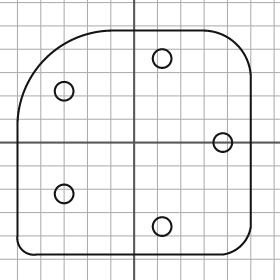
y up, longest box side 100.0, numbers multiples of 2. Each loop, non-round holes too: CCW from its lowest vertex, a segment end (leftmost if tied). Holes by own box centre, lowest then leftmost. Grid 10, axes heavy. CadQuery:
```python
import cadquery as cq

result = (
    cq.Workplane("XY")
    .moveTo(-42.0, -48.0)
    .lineTo(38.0, -48.0)
    .threePointArc((46.0, -44.0), (50.0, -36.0))
    .lineTo(50.0, 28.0)
    .threePointArc((44.0, 42.0), (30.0, 48.0))
    .lineTo(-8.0, 48.0)
    .threePointArc((-38.0, 36.0), (-50.0, 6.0))
    .lineTo(-50.0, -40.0)
    .threePointArc((-48.0, -46.0), (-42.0, -48.0))
    .close()
    .moveTo(12.0, -36.0)
    .circle(4.0)
    .moveTo(-30.0, -22.0)
    .circle(4.0)
    .moveTo(38.0, 0.0)
    .circle(4.0)
    .moveTo(-30.0, 22.0)
    .circle(4.0)
    .moveTo(12.0, 36.0)
    .circle(4.0)
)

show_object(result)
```